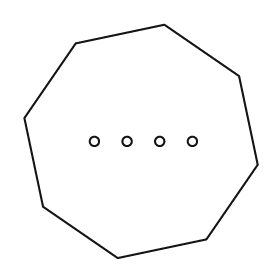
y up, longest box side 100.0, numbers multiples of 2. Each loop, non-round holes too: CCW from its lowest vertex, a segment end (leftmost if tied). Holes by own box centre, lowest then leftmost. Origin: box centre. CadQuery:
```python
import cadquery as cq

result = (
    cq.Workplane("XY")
    .moveTo(-10.0, -50.0)
    .lineTo(28.0, -42.0)
    .lineTo(50.0, -10.0)
    .lineTo(42.0, 28.0)
    .lineTo(10.0, 50.0)
    .lineTo(-28.0, 42.0)
    .lineTo(-50.0, 10.0)
    .lineTo(-42.0, -28.0)
    .close()
    .moveTo(-20.0, 0.0)
    .circle(2.0)
    .moveTo(-6.0, 0.0)
    .circle(2.0)
    .moveTo(8.0, 0.0)
    .circle(2.0)
    .moveTo(22.0, 0.0)
    .circle(2.0)
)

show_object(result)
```